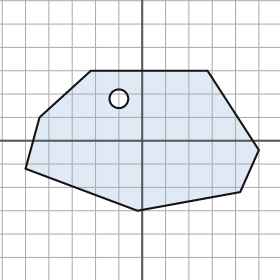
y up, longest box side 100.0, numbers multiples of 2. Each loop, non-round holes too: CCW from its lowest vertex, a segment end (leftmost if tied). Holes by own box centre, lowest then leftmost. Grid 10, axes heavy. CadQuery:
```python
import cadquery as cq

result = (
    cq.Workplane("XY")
    .moveTo(-2.0, -30.0)
    .lineTo(42.0, -22.0)
    .lineTo(50.0, -4.0)
    .lineTo(28.0, 30.0)
    .lineTo(-22.0, 30.0)
    .lineTo(-44.0, 10.0)
    .lineTo(-50.0, -12.0)
    .close()
    .moveTo(-10.0, 18.0)
    .circle(4.0)
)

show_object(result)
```